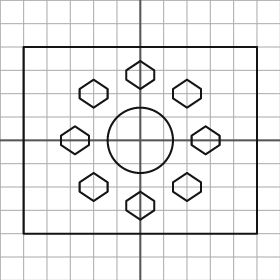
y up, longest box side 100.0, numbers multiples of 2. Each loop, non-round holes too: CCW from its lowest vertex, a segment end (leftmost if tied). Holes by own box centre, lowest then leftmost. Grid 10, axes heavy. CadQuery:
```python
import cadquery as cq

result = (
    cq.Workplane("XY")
    .moveTo(-50.0, -40.0)
    .lineTo(50.0, -40.0)
    .lineTo(50.0, 40.0)
    .lineTo(-50.0, 40.0)
    .close()
    .moveTo(0.0, -34.0)
    .lineTo(6.0, -30.0)
    .lineTo(6.0, -26.0)
    .lineTo(0.0, -22.0)
    .lineTo(-6.0, -26.0)
    .lineTo(-6.0, -30.0)
    .close()
    .moveTo(-20.0, -26.0)
    .lineTo(-14.0, -22.0)
    .lineTo(-14.0, -18.0)
    .lineTo(-20.0, -14.0)
    .lineTo(-26.0, -18.0)
    .lineTo(-26.0, -22.0)
    .close()
    .moveTo(20.0, -26.0)
    .lineTo(26.0, -22.0)
    .lineTo(26.0, -18.0)
    .lineTo(20.0, -14.0)
    .lineTo(14.0, -18.0)
    .lineTo(14.0, -22.0)
    .close()
    .moveTo(-28.0, -6.0)
    .lineTo(-22.0, -2.0)
    .lineTo(-22.0, 2.0)
    .lineTo(-28.0, 6.0)
    .lineTo(-34.0, 2.0)
    .lineTo(-34.0, -2.0)
    .close()
    .moveTo(0.0, 0.0)
    .circle(14.0)
    .moveTo(28.0, -6.0)
    .lineTo(34.0, -2.0)
    .lineTo(34.0, 2.0)
    .lineTo(28.0, 6.0)
    .lineTo(22.0, 2.0)
    .lineTo(22.0, -2.0)
    .close()
    .moveTo(-20.0, 14.0)
    .lineTo(-14.0, 18.0)
    .lineTo(-14.0, 22.0)
    .lineTo(-20.0, 26.0)
    .lineTo(-26.0, 22.0)
    .lineTo(-26.0, 18.0)
    .close()
    .moveTo(20.0, 14.0)
    .lineTo(26.0, 18.0)
    .lineTo(26.0, 22.0)
    .lineTo(20.0, 26.0)
    .lineTo(14.0, 22.0)
    .lineTo(14.0, 18.0)
    .close()
    .moveTo(0.0, 22.0)
    .lineTo(6.0, 26.0)
    .lineTo(6.0, 30.0)
    .lineTo(0.0, 34.0)
    .lineTo(-6.0, 30.0)
    .lineTo(-6.0, 26.0)
    .close()
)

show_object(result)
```